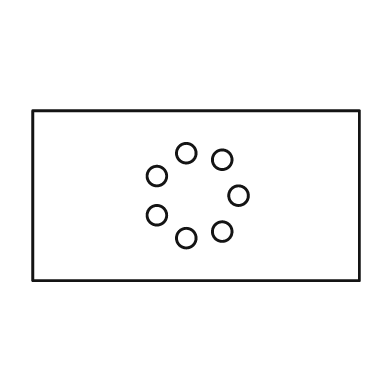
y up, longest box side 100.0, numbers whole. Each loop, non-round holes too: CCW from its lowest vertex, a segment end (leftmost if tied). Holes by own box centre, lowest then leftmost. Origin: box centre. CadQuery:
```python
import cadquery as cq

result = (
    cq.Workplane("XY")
    .moveTo(-50.0, -26.0)
    .lineTo(50.0, -26.0)
    .lineTo(50.0, 26.0)
    .lineTo(-50.0, 26.0)
    .close()
    .moveTo(-3.0, -13.0)
    .circle(3.0)
    .moveTo(8.0, -11.0)
    .circle(3.0)
    .moveTo(-12.0, -6.0)
    .circle(3.0)
    .moveTo(13.0, 0.0)
    .circle(3.0)
    .moveTo(-12.0, 6.0)
    .circle(3.0)
    .moveTo(8.0, 11.0)
    .circle(3.0)
    .moveTo(-3.0, 13.0)
    .circle(3.0)
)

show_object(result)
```